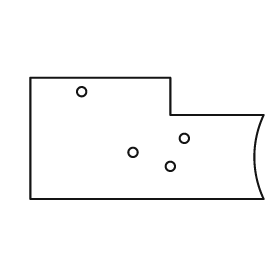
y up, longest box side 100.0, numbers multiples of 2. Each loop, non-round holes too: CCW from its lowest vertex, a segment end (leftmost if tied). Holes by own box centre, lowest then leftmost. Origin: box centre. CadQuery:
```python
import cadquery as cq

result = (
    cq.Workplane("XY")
    .moveTo(-50.0, -26.0)
    .lineTo(50.0, -26.0)
    .threePointArc((46.0, -8.0), (50.0, 10.0))
    .lineTo(10.0, 10.0)
    .lineTo(10.0, 26.0)
    .lineTo(-50.0, 26.0)
    .close()
    .moveTo(10.0, -12.0)
    .circle(2.0)
    .moveTo(-6.0, -6.0)
    .circle(2.0)
    .moveTo(16.0, 0.0)
    .circle(2.0)
    .moveTo(-28.0, 20.0)
    .circle(2.0)
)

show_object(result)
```